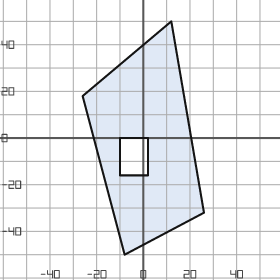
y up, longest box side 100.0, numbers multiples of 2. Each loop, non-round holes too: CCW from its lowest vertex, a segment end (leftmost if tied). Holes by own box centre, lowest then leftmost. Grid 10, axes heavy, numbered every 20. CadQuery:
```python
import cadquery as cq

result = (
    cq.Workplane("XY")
    .moveTo(-8.0, -50.0)
    .lineTo(26.0, -32.0)
    .lineTo(12.0, 50.0)
    .lineTo(-26.0, 18.0)
    .close()
    .moveTo(-10.0, -16.0)
    .lineTo(2.0, -16.0)
    .lineTo(2.0, 0.0)
    .lineTo(-10.0, 0.0)
    .close()
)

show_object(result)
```